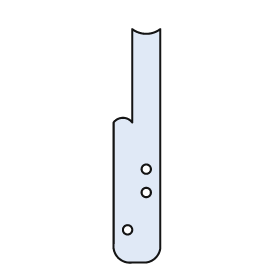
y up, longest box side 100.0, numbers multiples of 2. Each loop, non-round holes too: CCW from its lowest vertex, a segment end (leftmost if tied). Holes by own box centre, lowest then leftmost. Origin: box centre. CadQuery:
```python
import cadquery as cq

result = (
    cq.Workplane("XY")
    .moveTo(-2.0, -50.0)
    .lineTo(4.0, -50.0)
    .threePointArc((8.0, -48.0), (10.0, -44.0))
    .lineTo(10.0, 50.0)
    .threePointArc((4.0, 48.0), (-2.0, 50.0))
    .lineTo(-2.0, 10.0)
    .threePointArc((-6.0, 12.0), (-10.0, 10.0))
    .lineTo(-10.0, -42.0)
    .threePointArc((-8.0, -48.0), (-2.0, -50.0))
    .close()
    .moveTo(-4.0, -36.0)
    .circle(2.0)
    .moveTo(4.0, -20.0)
    .circle(2.0)
    .moveTo(4.0, -10.0)
    .circle(2.0)
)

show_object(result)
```